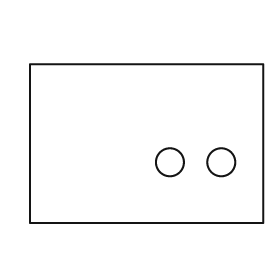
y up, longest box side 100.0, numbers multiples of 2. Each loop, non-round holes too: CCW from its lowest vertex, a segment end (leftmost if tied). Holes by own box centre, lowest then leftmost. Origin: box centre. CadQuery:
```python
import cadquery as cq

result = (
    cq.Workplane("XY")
    .moveTo(-50.0, -34.0)
    .lineTo(50.0, -34.0)
    .lineTo(50.0, 34.0)
    .lineTo(-50.0, 34.0)
    .close()
    .moveTo(10.0, -8.0)
    .circle(6.0)
    .moveTo(32.0, -8.0)
    .circle(6.0)
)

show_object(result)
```